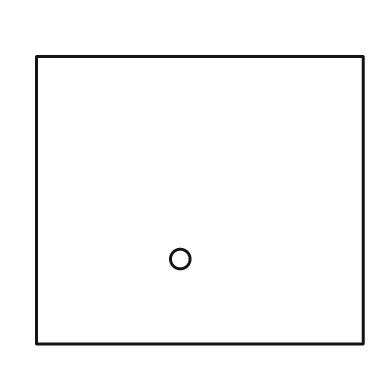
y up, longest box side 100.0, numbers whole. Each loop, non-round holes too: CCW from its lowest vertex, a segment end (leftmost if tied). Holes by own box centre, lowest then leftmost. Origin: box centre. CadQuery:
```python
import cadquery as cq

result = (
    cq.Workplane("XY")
    .moveTo(-50.0, -44.0)
    .lineTo(50.0, -44.0)
    .lineTo(50.0, 44.0)
    .lineTo(-50.0, 44.0)
    .close()
    .moveTo(-6.0, -18.0)
    .circle(3.0)
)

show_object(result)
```